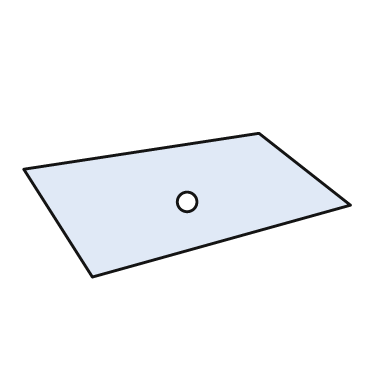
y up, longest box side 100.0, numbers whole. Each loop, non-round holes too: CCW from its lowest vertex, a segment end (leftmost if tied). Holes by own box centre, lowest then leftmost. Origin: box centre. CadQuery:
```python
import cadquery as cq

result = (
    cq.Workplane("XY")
    .moveTo(-29.0, -22.0)
    .lineTo(50.0, 0.0)
    .lineTo(22.0, 22.0)
    .lineTo(-50.0, 11.0)
    .close()
    .moveTo(0.0, 1.0)
    .circle(3.0)
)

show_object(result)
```